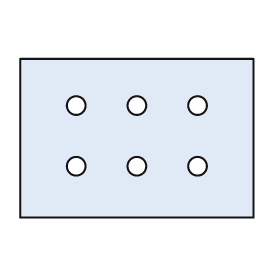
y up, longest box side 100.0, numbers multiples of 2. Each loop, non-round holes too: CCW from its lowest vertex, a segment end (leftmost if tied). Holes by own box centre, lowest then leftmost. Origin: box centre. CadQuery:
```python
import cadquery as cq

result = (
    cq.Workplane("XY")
    .moveTo(-50.0, -34.0)
    .lineTo(50.0, -34.0)
    .lineTo(50.0, 34.0)
    .lineTo(-50.0, 34.0)
    .close()
    .moveTo(-26.0, -12.0)
    .circle(4.0)
    .moveTo(0.0, -12.0)
    .circle(4.0)
    .moveTo(26.0, -12.0)
    .circle(4.0)
    .moveTo(-26.0, 14.0)
    .circle(4.0)
    .moveTo(0.0, 14.0)
    .circle(4.0)
    .moveTo(26.0, 14.0)
    .circle(4.0)
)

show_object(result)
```